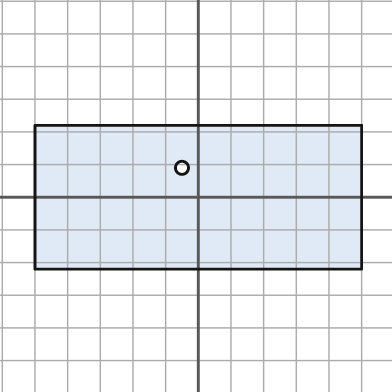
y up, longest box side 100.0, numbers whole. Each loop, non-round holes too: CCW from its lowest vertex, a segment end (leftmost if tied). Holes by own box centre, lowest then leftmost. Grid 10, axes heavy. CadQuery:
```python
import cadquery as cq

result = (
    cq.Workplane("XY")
    .moveTo(-50.0, -22.0)
    .lineTo(50.0, -22.0)
    .lineTo(50.0, 22.0)
    .lineTo(-50.0, 22.0)
    .close()
    .moveTo(-5.0, 9.0)
    .circle(2.0)
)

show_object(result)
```